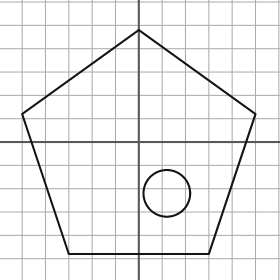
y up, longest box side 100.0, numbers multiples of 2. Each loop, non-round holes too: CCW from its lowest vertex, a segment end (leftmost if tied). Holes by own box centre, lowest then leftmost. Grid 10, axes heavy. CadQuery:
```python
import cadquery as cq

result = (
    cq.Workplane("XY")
    .moveTo(-30.0, -48.0)
    .lineTo(30.0, -48.0)
    .lineTo(50.0, 12.0)
    .lineTo(0.0, 48.0)
    .lineTo(-50.0, 12.0)
    .close()
    .moveTo(12.0, -22.0)
    .circle(10.0)
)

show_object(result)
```